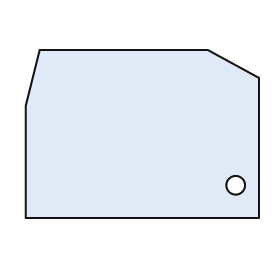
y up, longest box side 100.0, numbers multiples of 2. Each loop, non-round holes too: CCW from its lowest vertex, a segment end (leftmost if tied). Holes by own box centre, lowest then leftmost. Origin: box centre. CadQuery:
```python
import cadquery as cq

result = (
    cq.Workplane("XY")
    .moveTo(-50.0, -36.0)
    .lineTo(50.0, -36.0)
    .lineTo(50.0, 24.0)
    .lineTo(28.0, 36.0)
    .lineTo(-44.0, 36.0)
    .lineTo(-50.0, 12.0)
    .close()
    .moveTo(40.0, -22.0)
    .circle(4.0)
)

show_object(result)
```